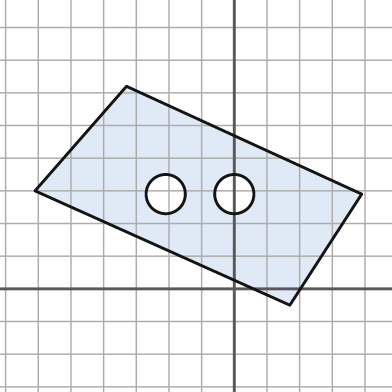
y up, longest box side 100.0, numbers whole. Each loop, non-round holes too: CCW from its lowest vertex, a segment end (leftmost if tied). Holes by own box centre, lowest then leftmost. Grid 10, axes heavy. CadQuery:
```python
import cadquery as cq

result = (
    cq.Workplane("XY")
    .moveTo(17.0, -5.0)
    .lineTo(39.0, 29.0)
    .lineTo(-33.0, 62.0)
    .lineTo(-61.0, 30.0)
    .close()
    .moveTo(-21.0, 29.0)
    .circle(6.0)
    .moveTo(0.0, 29.0)
    .circle(6.0)
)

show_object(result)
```